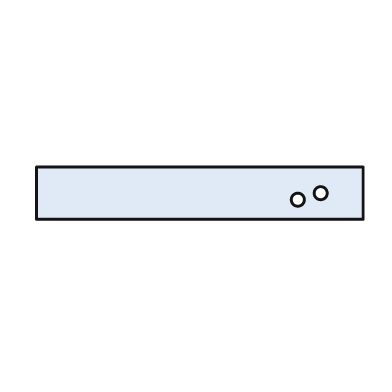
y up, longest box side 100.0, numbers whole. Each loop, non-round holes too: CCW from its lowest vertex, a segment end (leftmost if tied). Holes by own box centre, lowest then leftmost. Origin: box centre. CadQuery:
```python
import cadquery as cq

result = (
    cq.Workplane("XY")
    .moveTo(-50.0, -8.0)
    .lineTo(50.0, -8.0)
    .lineTo(50.0, 8.0)
    .lineTo(-50.0, 8.0)
    .close()
    .moveTo(30.0, -2.0)
    .circle(2.0)
    .moveTo(37.0, 0.0)
    .circle(2.0)
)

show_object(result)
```